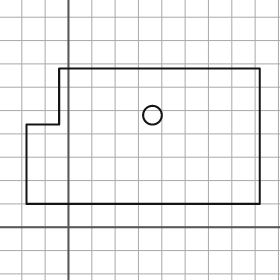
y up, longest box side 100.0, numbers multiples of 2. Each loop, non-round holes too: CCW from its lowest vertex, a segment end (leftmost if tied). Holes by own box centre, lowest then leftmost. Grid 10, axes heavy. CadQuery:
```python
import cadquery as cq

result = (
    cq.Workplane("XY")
    .moveTo(-18.0, 10.0)
    .lineTo(82.0, 10.0)
    .lineTo(82.0, 68.0)
    .lineTo(-4.0, 68.0)
    .lineTo(-4.0, 44.0)
    .lineTo(-18.0, 44.0)
    .close()
    .moveTo(36.0, 48.0)
    .circle(4.0)
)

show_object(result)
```